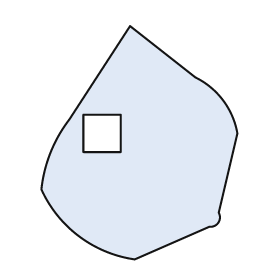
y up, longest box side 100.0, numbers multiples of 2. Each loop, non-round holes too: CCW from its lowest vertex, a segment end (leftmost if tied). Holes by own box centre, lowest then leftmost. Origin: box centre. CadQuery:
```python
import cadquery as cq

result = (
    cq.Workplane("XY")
    .moveTo(-2.0, -50.0)
    .lineTo(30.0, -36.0)
    .threePointArc((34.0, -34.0), (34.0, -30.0))
    .lineTo(42.0, 4.0)
    .threePointArc((36.0, 18.0), (24.0, 28.0))
    .lineTo(-4.0, 50.0)
    .lineTo(-30.0, 10.0)
    .threePointArc((-38.0, -4.0), (-42.0, -20.0))
    .threePointArc((-26.0, -40.0), (-2.0, -50.0))
    .close()
    .moveTo(-24.0, -4.0)
    .lineTo(-8.0, -4.0)
    .lineTo(-8.0, 12.0)
    .lineTo(-24.0, 12.0)
    .close()
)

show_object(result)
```